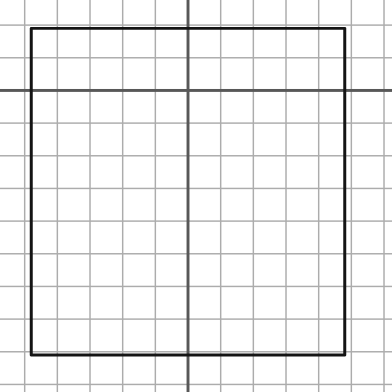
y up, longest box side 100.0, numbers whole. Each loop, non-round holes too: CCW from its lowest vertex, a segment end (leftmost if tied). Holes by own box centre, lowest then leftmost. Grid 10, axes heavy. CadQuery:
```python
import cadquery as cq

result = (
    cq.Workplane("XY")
    .moveTo(-48.0, -81.0)
    .lineTo(48.0, -81.0)
    .lineTo(48.0, 19.0)
    .lineTo(-48.0, 19.0)
    .close()
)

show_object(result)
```